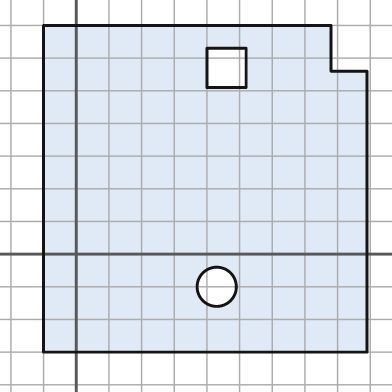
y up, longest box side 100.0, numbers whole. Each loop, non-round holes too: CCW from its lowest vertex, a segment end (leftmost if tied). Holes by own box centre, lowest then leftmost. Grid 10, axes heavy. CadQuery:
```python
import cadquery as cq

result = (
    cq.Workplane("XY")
    .moveTo(-10.0, -30.0)
    .lineTo(89.0, -30.0)
    .lineTo(89.0, 56.0)
    .lineTo(78.0, 56.0)
    .lineTo(78.0, 70.0)
    .lineTo(-10.0, 70.0)
    .close()
    .moveTo(43.0, -10.0)
    .circle(6.0)
    .moveTo(40.0, 51.0)
    .lineTo(52.0, 51.0)
    .lineTo(52.0, 63.0)
    .lineTo(40.0, 63.0)
    .close()
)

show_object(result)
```